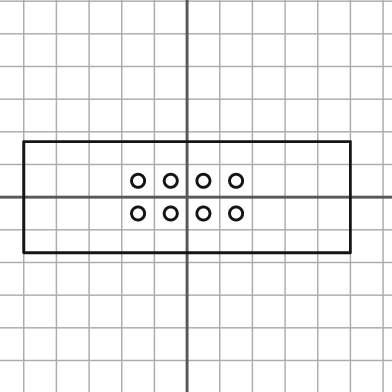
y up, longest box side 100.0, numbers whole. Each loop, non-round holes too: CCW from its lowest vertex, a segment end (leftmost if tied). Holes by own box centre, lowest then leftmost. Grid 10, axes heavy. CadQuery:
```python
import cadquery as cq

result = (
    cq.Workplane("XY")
    .moveTo(-50.0, -17.0)
    .lineTo(50.0, -17.0)
    .lineTo(50.0, 17.0)
    .lineTo(-50.0, 17.0)
    .close()
    .moveTo(-15.0, -5.0)
    .circle(2.0)
    .moveTo(-5.0, -5.0)
    .circle(2.0)
    .moveTo(5.0, -5.0)
    .circle(2.0)
    .moveTo(15.0, -5.0)
    .circle(2.0)
    .moveTo(-15.0, 5.0)
    .circle(2.0)
    .moveTo(-5.0, 5.0)
    .circle(2.0)
    .moveTo(5.0, 5.0)
    .circle(2.0)
    .moveTo(15.0, 5.0)
    .circle(2.0)
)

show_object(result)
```